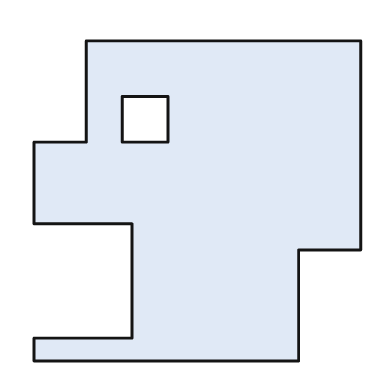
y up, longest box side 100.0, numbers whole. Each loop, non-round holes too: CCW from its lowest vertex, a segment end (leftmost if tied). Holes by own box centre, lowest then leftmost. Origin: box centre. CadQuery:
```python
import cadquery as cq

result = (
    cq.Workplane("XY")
    .moveTo(-50.0, -49.0)
    .lineTo(31.0, -49.0)
    .lineTo(31.0, -15.0)
    .lineTo(50.0, -15.0)
    .lineTo(50.0, 49.0)
    .lineTo(-34.0, 49.0)
    .lineTo(-34.0, 18.0)
    .lineTo(-50.0, 18.0)
    .lineTo(-50.0, -7.0)
    .lineTo(-20.0, -7.0)
    .lineTo(-20.0, -42.0)
    .lineTo(-50.0, -42.0)
    .close()
    .moveTo(-23.0, 18.0)
    .lineTo(-9.0, 18.0)
    .lineTo(-9.0, 32.0)
    .lineTo(-23.0, 32.0)
    .close()
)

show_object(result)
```